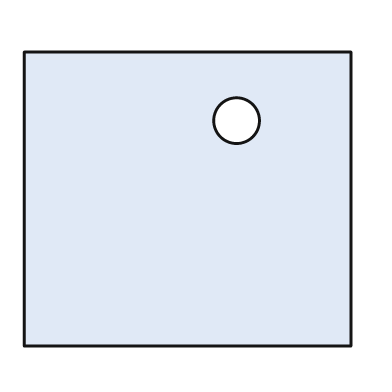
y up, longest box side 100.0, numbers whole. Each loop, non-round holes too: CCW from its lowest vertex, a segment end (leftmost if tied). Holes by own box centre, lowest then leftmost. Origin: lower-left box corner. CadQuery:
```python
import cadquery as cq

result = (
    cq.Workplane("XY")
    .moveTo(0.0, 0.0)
    .lineTo(100.0, 0.0)
    .lineTo(100.0, 90.0)
    .lineTo(0.0, 90.0)
    .close()
    .moveTo(65.0, 69.0)
    .circle(7.0)
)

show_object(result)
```